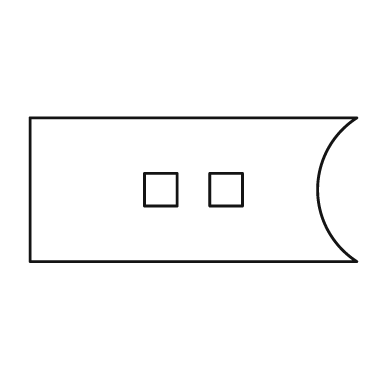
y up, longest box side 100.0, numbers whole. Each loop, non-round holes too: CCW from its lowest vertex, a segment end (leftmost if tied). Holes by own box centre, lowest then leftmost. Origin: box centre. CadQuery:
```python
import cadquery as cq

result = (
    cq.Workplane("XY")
    .moveTo(-50.0, -22.0)
    .lineTo(50.0, -22.0)
    .threePointArc((38.0, 0.0), (50.0, 22.0))
    .lineTo(-50.0, 22.0)
    .close()
    .moveTo(-15.0, -5.0)
    .lineTo(-5.0, -5.0)
    .lineTo(-5.0, 5.0)
    .lineTo(-15.0, 5.0)
    .close()
    .moveTo(5.0, -5.0)
    .lineTo(15.0, -5.0)
    .lineTo(15.0, 5.0)
    .lineTo(5.0, 5.0)
    .close()
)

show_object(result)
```